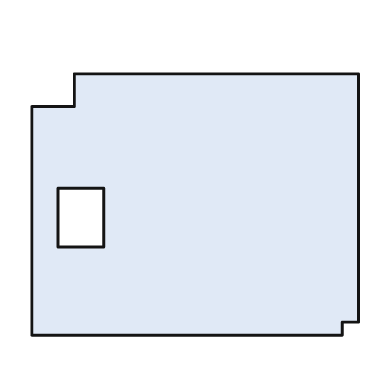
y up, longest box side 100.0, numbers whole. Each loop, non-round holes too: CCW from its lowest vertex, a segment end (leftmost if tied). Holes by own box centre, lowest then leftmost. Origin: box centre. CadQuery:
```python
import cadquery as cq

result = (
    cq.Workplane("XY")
    .moveTo(-50.0, -40.0)
    .lineTo(45.0, -40.0)
    .lineTo(45.0, -36.0)
    .lineTo(50.0, -36.0)
    .lineTo(50.0, 40.0)
    .lineTo(-37.0, 40.0)
    .lineTo(-37.0, 30.0)
    .lineTo(-50.0, 30.0)
    .close()
    .moveTo(-42.0, -13.0)
    .lineTo(-28.0, -13.0)
    .lineTo(-28.0, 5.0)
    .lineTo(-42.0, 5.0)
    .close()
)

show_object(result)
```